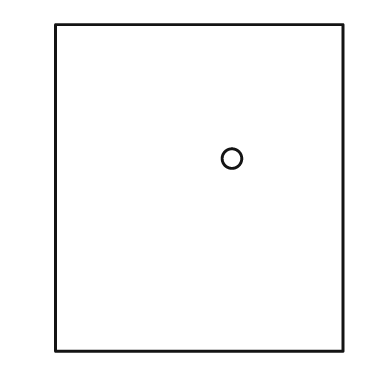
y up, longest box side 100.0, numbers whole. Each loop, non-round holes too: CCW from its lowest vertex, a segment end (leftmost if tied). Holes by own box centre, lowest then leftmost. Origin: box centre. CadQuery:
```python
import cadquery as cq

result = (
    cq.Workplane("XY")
    .moveTo(-44.0, -50.0)
    .lineTo(44.0, -50.0)
    .lineTo(44.0, 50.0)
    .lineTo(-44.0, 50.0)
    .close()
    .moveTo(10.0, 9.0)
    .circle(3.0)
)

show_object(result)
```